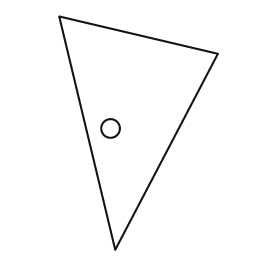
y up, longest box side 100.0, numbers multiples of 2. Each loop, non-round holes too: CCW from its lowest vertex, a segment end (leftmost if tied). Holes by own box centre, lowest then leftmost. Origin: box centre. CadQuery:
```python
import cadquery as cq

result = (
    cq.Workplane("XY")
    .moveTo(-10.0, -50.0)
    .lineTo(34.0, 34.0)
    .lineTo(-34.0, 50.0)
    .close()
    .moveTo(-12.0, 2.0)
    .circle(4.0)
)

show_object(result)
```